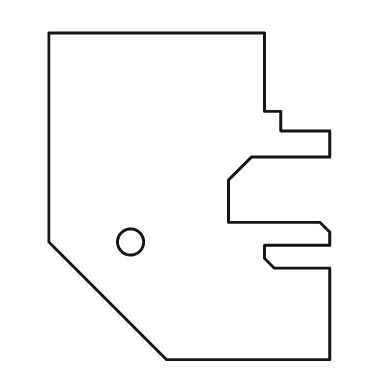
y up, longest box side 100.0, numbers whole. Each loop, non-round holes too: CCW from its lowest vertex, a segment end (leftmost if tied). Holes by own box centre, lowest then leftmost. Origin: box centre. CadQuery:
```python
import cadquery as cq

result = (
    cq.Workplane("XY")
    .moveTo(-7.0, -50.0)
    .lineTo(43.0, -50.0)
    .lineTo(43.0, -22.0)
    .lineTo(26.0, -22.0)
    .lineTo(23.0, -19.0)
    .lineTo(23.0, -15.0)
    .lineTo(43.0, -15.0)
    .lineTo(43.0, -11.0)
    .lineTo(40.0, -8.0)
    .lineTo(12.0, -8.0)
    .lineTo(12.0, 5.0)
    .lineTo(19.0, 12.0)
    .lineTo(43.0, 12.0)
    .lineTo(43.0, 20.0)
    .lineTo(28.0, 20.0)
    .lineTo(28.0, 26.0)
    .lineTo(23.0, 26.0)
    .lineTo(23.0, 50.0)
    .lineTo(-43.0, 50.0)
    .lineTo(-43.0, -14.0)
    .close()
    .moveTo(-18.0, -14.0)
    .circle(4.0)
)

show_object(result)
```